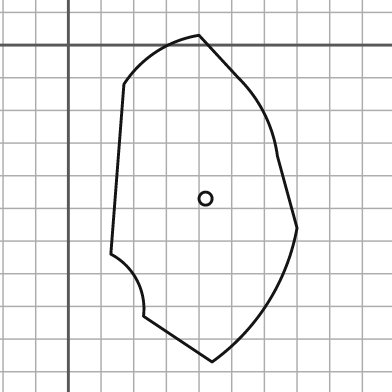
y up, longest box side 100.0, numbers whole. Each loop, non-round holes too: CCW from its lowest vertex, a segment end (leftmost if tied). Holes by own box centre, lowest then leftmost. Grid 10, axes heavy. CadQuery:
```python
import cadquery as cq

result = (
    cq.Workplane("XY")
    .moveTo(44.0, -97.0)
    .threePointArc((61.0, -79.0), (70.0, -56.0))
    .lineTo(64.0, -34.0)
    .threePointArc((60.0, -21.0), (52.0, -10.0))
    .lineTo(40.0, 3.0)
    .threePointArc((27.0, -2.0), (17.0, -12.0))
    .lineTo(13.0, -64.0)
    .threePointArc((21.0, -72.0), (23.0, -83.0))
    .close()
    .moveTo(42.0, -47.0)
    .circle(2.0)
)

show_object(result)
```